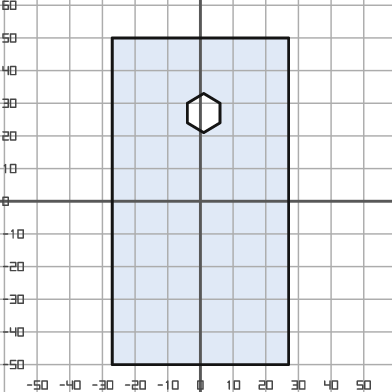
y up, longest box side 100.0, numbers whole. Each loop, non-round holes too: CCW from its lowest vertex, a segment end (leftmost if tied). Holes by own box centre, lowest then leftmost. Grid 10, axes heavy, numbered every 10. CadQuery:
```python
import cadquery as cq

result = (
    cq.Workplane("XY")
    .moveTo(-27.0, -50.0)
    .lineTo(27.0, -50.0)
    .lineTo(27.0, 50.0)
    .lineTo(-27.0, 50.0)
    .close()
    .moveTo(1.0, 21.0)
    .lineTo(6.0, 24.0)
    .lineTo(6.0, 30.0)
    .lineTo(1.0, 33.0)
    .lineTo(-4.0, 30.0)
    .lineTo(-4.0, 24.0)
    .close()
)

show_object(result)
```